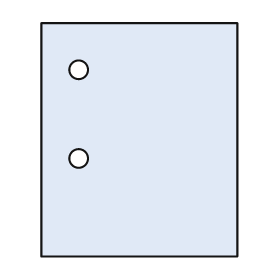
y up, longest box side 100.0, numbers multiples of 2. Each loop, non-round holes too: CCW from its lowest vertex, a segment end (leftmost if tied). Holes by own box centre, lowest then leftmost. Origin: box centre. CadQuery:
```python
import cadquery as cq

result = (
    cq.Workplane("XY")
    .moveTo(-42.0, -50.0)
    .lineTo(42.0, -50.0)
    .lineTo(42.0, 50.0)
    .lineTo(-42.0, 50.0)
    .close()
    .moveTo(-26.0, -8.0)
    .circle(4.0)
    .moveTo(-26.0, 30.0)
    .circle(4.0)
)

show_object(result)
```